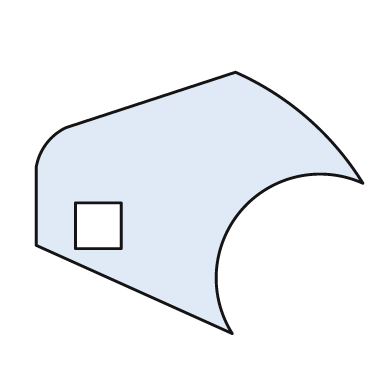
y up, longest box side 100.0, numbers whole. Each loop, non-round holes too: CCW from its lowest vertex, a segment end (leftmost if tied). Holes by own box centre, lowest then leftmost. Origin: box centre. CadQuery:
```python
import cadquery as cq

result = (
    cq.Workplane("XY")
    .moveTo(10.0, -40.0)
    .threePointArc((13.0, -2.0), (50.0, 6.0))
    .threePointArc((33.0, 26.0), (11.0, 40.0))
    .lineTo(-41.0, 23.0)
    .threePointArc((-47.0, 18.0), (-50.0, 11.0))
    .lineTo(-50.0, -13.0)
    .close()
    .moveTo(-38.0, -14.0)
    .lineTo(-24.0, -14.0)
    .lineTo(-24.0, 0.0)
    .lineTo(-38.0, 0.0)
    .close()
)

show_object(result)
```